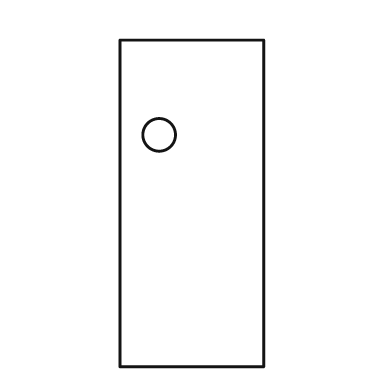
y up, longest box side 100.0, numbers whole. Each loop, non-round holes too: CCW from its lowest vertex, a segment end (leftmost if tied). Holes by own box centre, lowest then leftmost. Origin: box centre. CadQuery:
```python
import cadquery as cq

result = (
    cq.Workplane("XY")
    .moveTo(-22.0, -50.0)
    .lineTo(22.0, -50.0)
    .lineTo(22.0, 50.0)
    .lineTo(-22.0, 50.0)
    .close()
    .moveTo(-10.0, 21.0)
    .circle(5.0)
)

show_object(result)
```